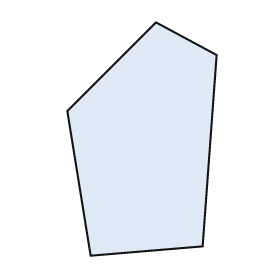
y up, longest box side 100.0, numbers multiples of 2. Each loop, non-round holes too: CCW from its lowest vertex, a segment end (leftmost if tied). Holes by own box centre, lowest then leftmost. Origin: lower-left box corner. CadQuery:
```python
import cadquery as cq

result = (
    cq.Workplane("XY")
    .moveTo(10.0, 0.0)
    .lineTo(58.0, 4.0)
    .lineTo(64.0, 86.0)
    .lineTo(38.0, 100.0)
    .lineTo(0.0, 62.0)
    .close()
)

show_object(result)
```